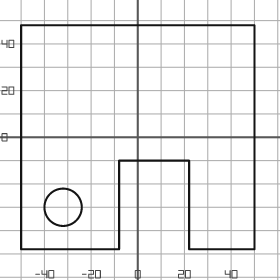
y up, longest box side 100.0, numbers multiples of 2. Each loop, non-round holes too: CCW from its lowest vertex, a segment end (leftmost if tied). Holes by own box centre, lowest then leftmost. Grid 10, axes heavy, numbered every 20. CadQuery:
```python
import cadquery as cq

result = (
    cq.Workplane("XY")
    .moveTo(-50.0, -48.0)
    .lineTo(-8.0, -48.0)
    .lineTo(-8.0, -10.0)
    .lineTo(22.0, -10.0)
    .lineTo(22.0, -48.0)
    .lineTo(50.0, -48.0)
    .lineTo(50.0, 48.0)
    .lineTo(-50.0, 48.0)
    .close()
    .moveTo(-32.0, -30.0)
    .circle(8.0)
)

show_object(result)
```